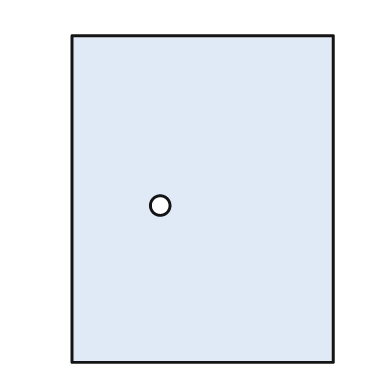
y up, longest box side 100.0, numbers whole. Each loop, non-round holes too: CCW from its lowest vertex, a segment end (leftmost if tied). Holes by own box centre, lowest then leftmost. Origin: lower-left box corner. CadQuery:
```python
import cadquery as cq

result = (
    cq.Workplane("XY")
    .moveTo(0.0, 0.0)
    .lineTo(80.0, 0.0)
    .lineTo(80.0, 100.0)
    .lineTo(0.0, 100.0)
    .close()
    .moveTo(27.0, 48.0)
    .circle(3.0)
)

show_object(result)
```